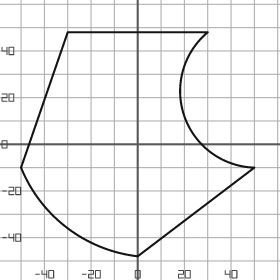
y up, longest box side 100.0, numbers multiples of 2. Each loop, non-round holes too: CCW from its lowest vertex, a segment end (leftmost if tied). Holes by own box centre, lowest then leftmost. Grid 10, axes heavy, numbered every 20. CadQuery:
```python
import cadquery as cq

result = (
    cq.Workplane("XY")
    .moveTo(0.0, -48.0)
    .lineTo(50.0, -10.0)
    .threePointArc((20.0, 12.0), (30.0, 48.0))
    .lineTo(-30.0, 48.0)
    .lineTo(-50.0, -10.0)
    .threePointArc((-30.0, -36.0), (0.0, -48.0))
    .close()
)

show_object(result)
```